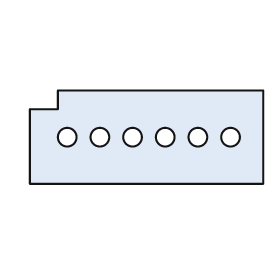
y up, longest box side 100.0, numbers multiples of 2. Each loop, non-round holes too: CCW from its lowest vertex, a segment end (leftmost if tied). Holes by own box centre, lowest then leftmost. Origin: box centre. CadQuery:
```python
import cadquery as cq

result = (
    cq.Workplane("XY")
    .moveTo(-50.0, -20.0)
    .lineTo(50.0, -20.0)
    .lineTo(50.0, 20.0)
    .lineTo(-38.0, 20.0)
    .lineTo(-38.0, 12.0)
    .lineTo(-50.0, 12.0)
    .close()
    .moveTo(-34.0, 0.0)
    .circle(4.0)
    .moveTo(-20.0, 0.0)
    .circle(4.0)
    .moveTo(-6.0, 0.0)
    .circle(4.0)
    .moveTo(8.0, 0.0)
    .circle(4.0)
    .moveTo(22.0, 0.0)
    .circle(4.0)
    .moveTo(36.0, 0.0)
    .circle(4.0)
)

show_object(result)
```